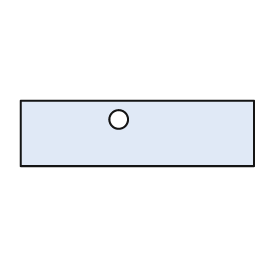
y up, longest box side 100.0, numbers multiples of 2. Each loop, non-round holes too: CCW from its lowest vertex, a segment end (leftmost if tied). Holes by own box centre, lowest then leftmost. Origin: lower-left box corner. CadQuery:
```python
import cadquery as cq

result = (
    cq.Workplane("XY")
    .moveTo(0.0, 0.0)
    .lineTo(100.0, 0.0)
    .lineTo(100.0, 28.0)
    .lineTo(0.0, 28.0)
    .close()
    .moveTo(42.0, 20.0)
    .circle(4.0)
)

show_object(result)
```